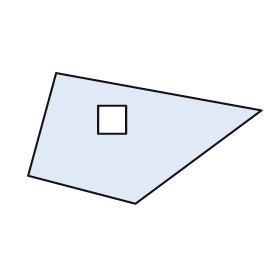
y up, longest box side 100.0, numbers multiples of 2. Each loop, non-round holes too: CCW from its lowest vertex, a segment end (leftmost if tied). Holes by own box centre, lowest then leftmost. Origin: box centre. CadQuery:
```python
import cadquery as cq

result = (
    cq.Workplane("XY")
    .moveTo(-4.0, -28.0)
    .lineTo(50.0, 12.0)
    .lineTo(-38.0, 28.0)
    .lineTo(-50.0, -16.0)
    .close()
    .moveTo(-20.0, 2.0)
    .lineTo(-8.0, 2.0)
    .lineTo(-8.0, 14.0)
    .lineTo(-20.0, 14.0)
    .close()
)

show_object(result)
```